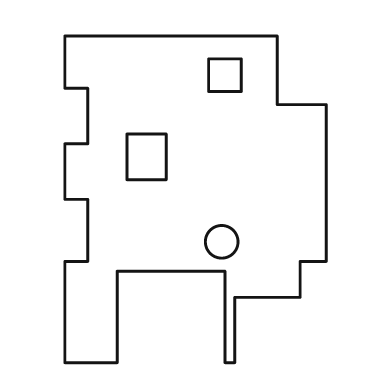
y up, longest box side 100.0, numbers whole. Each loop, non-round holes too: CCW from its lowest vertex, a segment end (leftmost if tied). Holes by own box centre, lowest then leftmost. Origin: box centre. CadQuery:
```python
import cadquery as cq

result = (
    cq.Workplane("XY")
    .moveTo(-40.0, -50.0)
    .lineTo(-24.0, -50.0)
    .lineTo(-24.0, -22.0)
    .lineTo(9.0, -22.0)
    .lineTo(9.0, -50.0)
    .lineTo(12.0, -50.0)
    .lineTo(12.0, -30.0)
    .lineTo(32.0, -30.0)
    .lineTo(32.0, -19.0)
    .lineTo(40.0, -19.0)
    .lineTo(40.0, 29.0)
    .lineTo(25.0, 29.0)
    .lineTo(25.0, 50.0)
    .lineTo(-40.0, 50.0)
    .lineTo(-40.0, 34.0)
    .lineTo(-33.0, 34.0)
    .lineTo(-33.0, 17.0)
    .lineTo(-40.0, 17.0)
    .lineTo(-40.0, 0.0)
    .lineTo(-33.0, 0.0)
    .lineTo(-33.0, -19.0)
    .lineTo(-40.0, -19.0)
    .close()
    .moveTo(8.0, -13.0)
    .circle(5.0)
    .moveTo(-21.0, 6.0)
    .lineTo(-9.0, 6.0)
    .lineTo(-9.0, 20.0)
    .lineTo(-21.0, 20.0)
    .close()
    .moveTo(4.0, 33.0)
    .lineTo(14.0, 33.0)
    .lineTo(14.0, 43.0)
    .lineTo(4.0, 43.0)
    .close()
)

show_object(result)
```